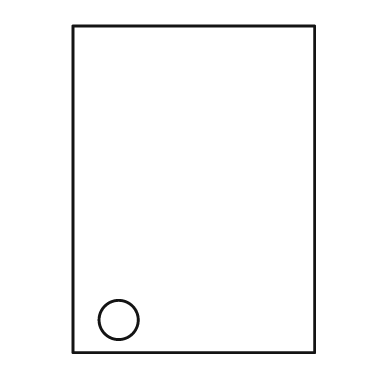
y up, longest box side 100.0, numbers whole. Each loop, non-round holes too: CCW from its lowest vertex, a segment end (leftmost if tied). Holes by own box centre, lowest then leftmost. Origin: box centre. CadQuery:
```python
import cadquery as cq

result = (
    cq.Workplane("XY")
    .moveTo(-37.0, -50.0)
    .lineTo(37.0, -50.0)
    .lineTo(37.0, 50.0)
    .lineTo(-37.0, 50.0)
    .close()
    .moveTo(-23.0, -40.0)
    .circle(6.0)
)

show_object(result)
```